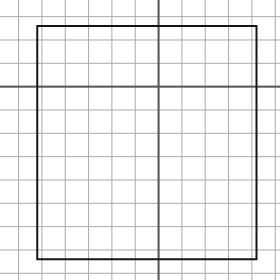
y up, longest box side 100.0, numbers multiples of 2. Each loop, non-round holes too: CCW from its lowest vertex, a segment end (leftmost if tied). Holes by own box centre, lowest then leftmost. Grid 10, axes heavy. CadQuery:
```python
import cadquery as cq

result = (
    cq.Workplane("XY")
    .moveTo(-52.0, -74.0)
    .lineTo(42.0, -74.0)
    .lineTo(42.0, 26.0)
    .lineTo(-52.0, 26.0)
    .close()
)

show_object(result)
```